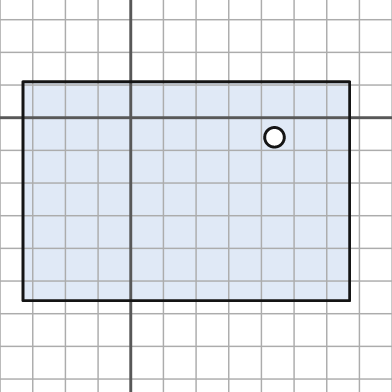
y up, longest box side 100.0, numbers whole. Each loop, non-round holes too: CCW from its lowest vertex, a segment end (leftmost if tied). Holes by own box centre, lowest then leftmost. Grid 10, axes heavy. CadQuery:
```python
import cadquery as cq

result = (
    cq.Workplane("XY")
    .moveTo(-33.0, -56.0)
    .lineTo(67.0, -56.0)
    .lineTo(67.0, 11.0)
    .lineTo(-33.0, 11.0)
    .close()
    .moveTo(44.0, -6.0)
    .circle(3.0)
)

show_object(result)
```